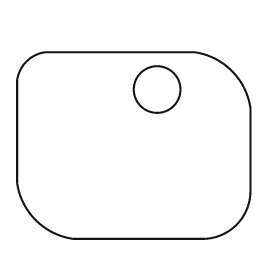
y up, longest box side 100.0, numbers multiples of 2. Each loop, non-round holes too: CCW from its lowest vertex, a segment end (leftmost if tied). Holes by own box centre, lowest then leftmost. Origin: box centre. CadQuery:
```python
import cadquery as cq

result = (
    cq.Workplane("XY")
    .moveTo(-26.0, -40.0)
    .lineTo(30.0, -40.0)
    .threePointArc((44.0, -34.0), (50.0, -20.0))
    .lineTo(50.0, 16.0)
    .threePointArc((42.0, 32.0), (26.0, 40.0))
    .lineTo(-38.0, 40.0)
    .threePointArc((-46.0, 36.0), (-50.0, 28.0))
    .lineTo(-50.0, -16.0)
    .threePointArc((-42.0, -32.0), (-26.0, -40.0))
    .close()
    .moveTo(10.0, 24.0)
    .circle(10.0)
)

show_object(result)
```